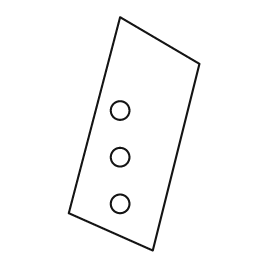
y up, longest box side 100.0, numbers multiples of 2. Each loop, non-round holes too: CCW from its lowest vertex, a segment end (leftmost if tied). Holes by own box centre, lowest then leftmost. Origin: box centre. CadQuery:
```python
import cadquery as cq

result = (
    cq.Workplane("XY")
    .moveTo(8.0, -50.0)
    .lineTo(28.0, 30.0)
    .lineTo(-6.0, 50.0)
    .lineTo(-28.0, -34.0)
    .close()
    .moveTo(-6.0, -30.0)
    .circle(4.0)
    .moveTo(-6.0, -10.0)
    .circle(4.0)
    .moveTo(-6.0, 10.0)
    .circle(4.0)
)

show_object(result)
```